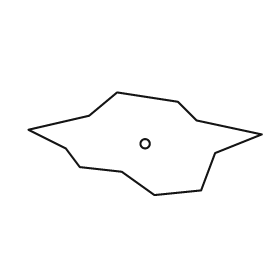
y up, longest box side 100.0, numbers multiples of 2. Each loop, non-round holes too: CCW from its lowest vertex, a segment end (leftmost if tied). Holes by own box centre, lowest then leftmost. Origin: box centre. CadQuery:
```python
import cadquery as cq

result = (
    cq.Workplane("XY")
    .moveTo(4.0, -22.0)
    .lineTo(24.0, -20.0)
    .lineTo(30.0, -4.0)
    .lineTo(50.0, 4.0)
    .lineTo(22.0, 10.0)
    .lineTo(14.0, 18.0)
    .lineTo(-12.0, 22.0)
    .lineTo(-24.0, 12.0)
    .lineTo(-50.0, 6.0)
    .lineTo(-34.0, -2.0)
    .lineTo(-28.0, -10.0)
    .lineTo(-10.0, -12.0)
    .close()
    .moveTo(0.0, 0.0)
    .circle(2.0)
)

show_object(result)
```